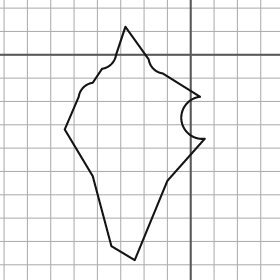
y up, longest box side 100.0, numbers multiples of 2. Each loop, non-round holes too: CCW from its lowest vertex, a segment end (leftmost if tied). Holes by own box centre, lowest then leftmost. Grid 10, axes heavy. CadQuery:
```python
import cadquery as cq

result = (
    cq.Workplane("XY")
    .moveTo(-24.0, -88.0)
    .lineTo(-10.0, -54.0)
    .lineTo(6.0, -36.0)
    .threePointArc((-4.0, -28.0), (4.0, -18.0))
    .lineTo(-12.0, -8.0)
    .threePointArc((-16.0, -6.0), (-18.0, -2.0))
    .lineTo(-28.0, 12.0)
    .lineTo(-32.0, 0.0)
    .threePointArc((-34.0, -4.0), (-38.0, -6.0))
    .lineTo(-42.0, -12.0)
    .threePointArc((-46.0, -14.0), (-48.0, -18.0))
    .lineTo(-54.0, -32.0)
    .lineTo(-42.0, -52.0)
    .lineTo(-34.0, -82.0)
    .close()
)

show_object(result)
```